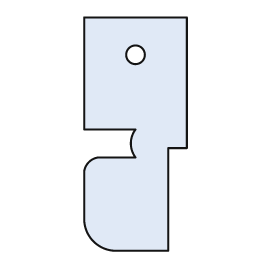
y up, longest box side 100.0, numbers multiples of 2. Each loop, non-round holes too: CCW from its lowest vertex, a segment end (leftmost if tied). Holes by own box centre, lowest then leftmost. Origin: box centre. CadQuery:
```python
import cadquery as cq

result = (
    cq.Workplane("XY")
    .moveTo(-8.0, -50.0)
    .lineTo(14.0, -50.0)
    .lineTo(14.0, -6.0)
    .lineTo(22.0, -6.0)
    .lineTo(22.0, 50.0)
    .lineTo(-22.0, 50.0)
    .lineTo(-22.0, 2.0)
    .lineTo(0.0, 2.0)
    .threePointArc((-2.0, -4.0), (0.0, -10.0))
    .lineTo(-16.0, -10.0)
    .threePointArc((-20.0, -12.0), (-22.0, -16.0))
    .lineTo(-22.0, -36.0)
    .threePointArc((-18.0, -46.0), (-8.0, -50.0))
    .close()
    .moveTo(0.0, 34.0)
    .circle(4.0)
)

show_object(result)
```